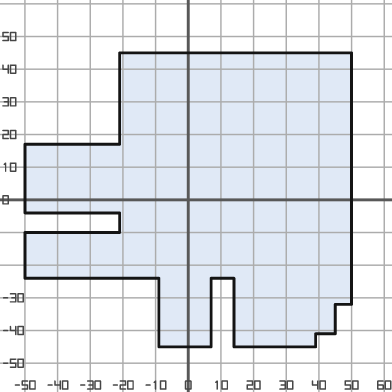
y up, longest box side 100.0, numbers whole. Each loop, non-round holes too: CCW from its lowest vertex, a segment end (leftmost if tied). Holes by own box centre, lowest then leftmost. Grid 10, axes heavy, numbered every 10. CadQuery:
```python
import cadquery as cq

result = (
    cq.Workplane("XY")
    .moveTo(-9.0, -45.0)
    .lineTo(7.0, -45.0)
    .lineTo(7.0, -24.0)
    .lineTo(14.0, -24.0)
    .lineTo(14.0, -45.0)
    .lineTo(39.0, -45.0)
    .lineTo(39.0, -41.0)
    .lineTo(45.0, -41.0)
    .lineTo(45.0, -32.0)
    .lineTo(50.0, -32.0)
    .lineTo(50.0, 45.0)
    .lineTo(-21.0, 45.0)
    .lineTo(-21.0, 17.0)
    .lineTo(-50.0, 17.0)
    .lineTo(-50.0, -4.0)
    .lineTo(-21.0, -4.0)
    .lineTo(-21.0, -10.0)
    .lineTo(-50.0, -10.0)
    .lineTo(-50.0, -24.0)
    .lineTo(-9.0, -24.0)
    .close()
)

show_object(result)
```